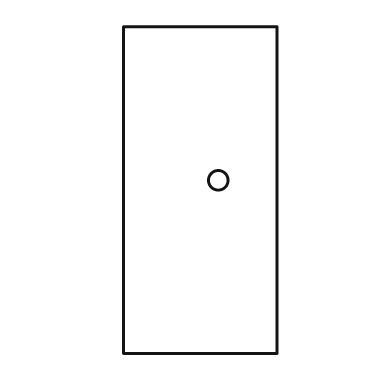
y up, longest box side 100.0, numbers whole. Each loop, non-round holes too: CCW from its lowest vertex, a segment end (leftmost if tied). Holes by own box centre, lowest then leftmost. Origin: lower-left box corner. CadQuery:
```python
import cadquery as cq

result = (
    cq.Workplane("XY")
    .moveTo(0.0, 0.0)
    .lineTo(47.0, 0.0)
    .lineTo(47.0, 100.0)
    .lineTo(0.0, 100.0)
    .close()
    .moveTo(29.0, 53.0)
    .circle(3.0)
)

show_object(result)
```